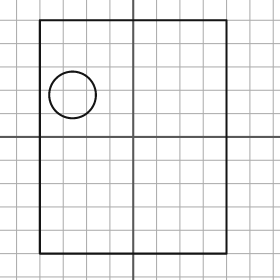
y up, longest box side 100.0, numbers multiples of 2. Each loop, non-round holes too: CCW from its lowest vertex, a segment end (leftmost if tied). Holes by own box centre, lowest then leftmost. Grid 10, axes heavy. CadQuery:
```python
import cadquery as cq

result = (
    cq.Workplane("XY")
    .moveTo(-40.0, -50.0)
    .lineTo(40.0, -50.0)
    .lineTo(40.0, 50.0)
    .lineTo(-40.0, 50.0)
    .close()
    .moveTo(-26.0, 18.0)
    .circle(10.0)
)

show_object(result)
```